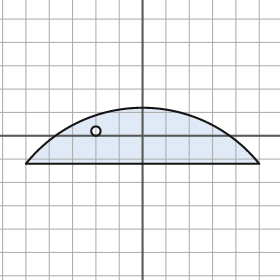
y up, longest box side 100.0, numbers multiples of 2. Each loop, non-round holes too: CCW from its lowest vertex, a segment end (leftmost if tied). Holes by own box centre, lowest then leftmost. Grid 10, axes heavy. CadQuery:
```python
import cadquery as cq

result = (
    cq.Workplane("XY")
    .moveTo(-50.0, -12.0)
    .lineTo(50.0, -12.0)
    .threePointArc((0.0, 12.0), (-50.0, -12.0))
    .close()
    .moveTo(-20.0, 2.0)
    .circle(2.0)
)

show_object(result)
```